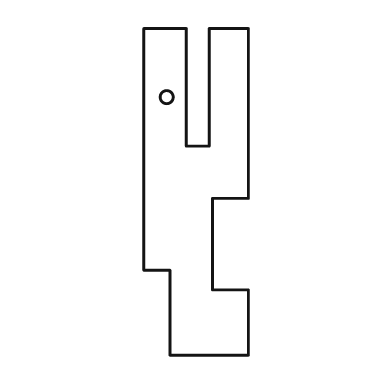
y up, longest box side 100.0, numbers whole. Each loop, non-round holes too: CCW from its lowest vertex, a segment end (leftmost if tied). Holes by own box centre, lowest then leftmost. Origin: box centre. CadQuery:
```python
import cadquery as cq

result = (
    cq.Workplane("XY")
    .moveTo(-8.0, -50.0)
    .lineTo(16.0, -50.0)
    .lineTo(16.0, -30.0)
    .lineTo(5.0, -30.0)
    .lineTo(5.0, -2.0)
    .lineTo(16.0, -2.0)
    .lineTo(16.0, 50.0)
    .lineTo(4.0, 50.0)
    .lineTo(4.0, 14.0)
    .lineTo(-3.0, 14.0)
    .lineTo(-3.0, 50.0)
    .lineTo(-16.0, 50.0)
    .lineTo(-16.0, -24.0)
    .lineTo(-8.0, -24.0)
    .close()
    .moveTo(-9.0, 29.0)
    .circle(2.0)
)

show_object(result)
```